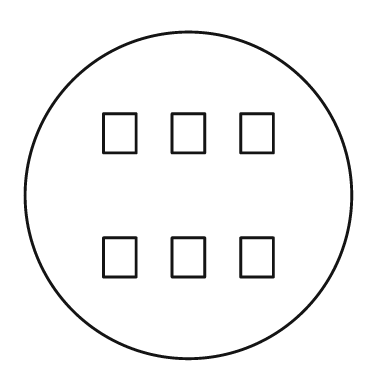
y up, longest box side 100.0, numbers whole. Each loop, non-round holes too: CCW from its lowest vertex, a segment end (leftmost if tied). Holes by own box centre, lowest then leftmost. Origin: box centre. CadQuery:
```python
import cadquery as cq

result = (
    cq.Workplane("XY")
    .moveTo(0.0, 0.0)
    .circle(50.0)
    .moveTo(-26.0, -25.0)
    .lineTo(-16.0, -25.0)
    .lineTo(-16.0, -13.0)
    .lineTo(-26.0, -13.0)
    .close()
    .moveTo(-5.0, -25.0)
    .lineTo(5.0, -25.0)
    .lineTo(5.0, -13.0)
    .lineTo(-5.0, -13.0)
    .close()
    .moveTo(16.0, -25.0)
    .lineTo(26.0, -25.0)
    .lineTo(26.0, -13.0)
    .lineTo(16.0, -13.0)
    .close()
    .moveTo(-26.0, 13.0)
    .lineTo(-16.0, 13.0)
    .lineTo(-16.0, 25.0)
    .lineTo(-26.0, 25.0)
    .close()
    .moveTo(-5.0, 13.0)
    .lineTo(5.0, 13.0)
    .lineTo(5.0, 25.0)
    .lineTo(-5.0, 25.0)
    .close()
    .moveTo(16.0, 13.0)
    .lineTo(26.0, 13.0)
    .lineTo(26.0, 25.0)
    .lineTo(16.0, 25.0)
    .close()
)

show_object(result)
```